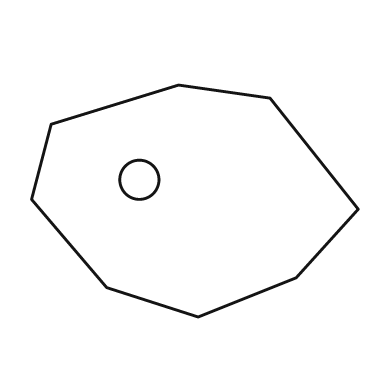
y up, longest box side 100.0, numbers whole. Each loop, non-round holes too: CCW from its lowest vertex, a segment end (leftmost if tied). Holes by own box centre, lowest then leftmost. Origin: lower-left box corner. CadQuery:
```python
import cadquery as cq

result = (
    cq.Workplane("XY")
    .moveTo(51.0, 0.0)
    .lineTo(81.0, 12.0)
    .lineTo(100.0, 33.0)
    .lineTo(73.0, 67.0)
    .lineTo(45.0, 71.0)
    .lineTo(6.0, 59.0)
    .lineTo(0.0, 36.0)
    .lineTo(23.0, 9.0)
    .close()
    .moveTo(33.0, 42.0)
    .circle(6.0)
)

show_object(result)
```